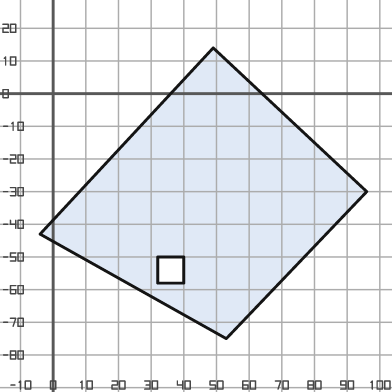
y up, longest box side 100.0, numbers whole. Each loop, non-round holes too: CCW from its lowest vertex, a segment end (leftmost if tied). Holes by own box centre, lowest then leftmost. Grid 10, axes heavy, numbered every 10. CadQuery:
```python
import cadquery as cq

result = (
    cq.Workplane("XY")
    .moveTo(53.0, -75.0)
    .lineTo(96.0, -30.0)
    .lineTo(49.0, 14.0)
    .lineTo(-4.0, -43.0)
    .close()
    .moveTo(32.0, -58.0)
    .lineTo(40.0, -58.0)
    .lineTo(40.0, -50.0)
    .lineTo(32.0, -50.0)
    .close()
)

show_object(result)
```